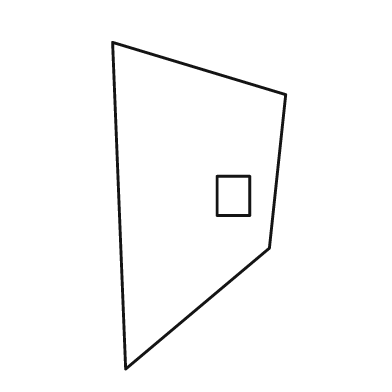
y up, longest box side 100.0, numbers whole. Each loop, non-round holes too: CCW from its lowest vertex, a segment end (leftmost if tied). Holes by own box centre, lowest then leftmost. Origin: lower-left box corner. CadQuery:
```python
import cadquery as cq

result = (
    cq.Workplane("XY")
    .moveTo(4.0, 0.0)
    .lineTo(48.0, 37.0)
    .lineTo(53.0, 84.0)
    .lineTo(0.0, 100.0)
    .close()
    .moveTo(32.0, 47.0)
    .lineTo(42.0, 47.0)
    .lineTo(42.0, 59.0)
    .lineTo(32.0, 59.0)
    .close()
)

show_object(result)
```